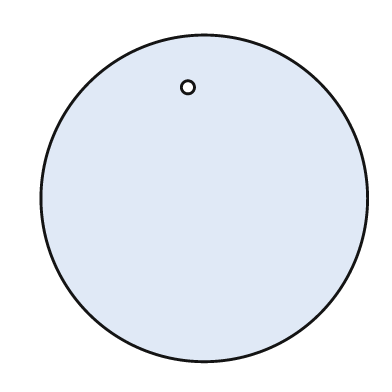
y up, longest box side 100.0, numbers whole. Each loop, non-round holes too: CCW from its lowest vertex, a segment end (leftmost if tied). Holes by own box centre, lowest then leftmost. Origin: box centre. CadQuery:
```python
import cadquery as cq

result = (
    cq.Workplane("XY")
    .moveTo(0.0, 0.0)
    .circle(50.0)
    .moveTo(-5.0, 34.0)
    .circle(2.0)
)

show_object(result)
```